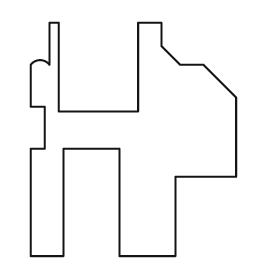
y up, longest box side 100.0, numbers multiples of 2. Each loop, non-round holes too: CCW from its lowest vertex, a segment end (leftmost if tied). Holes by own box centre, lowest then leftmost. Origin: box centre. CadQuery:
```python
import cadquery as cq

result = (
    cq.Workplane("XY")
    .moveTo(-44.0, -50.0)
    .lineTo(-30.0, -50.0)
    .lineTo(-30.0, -4.0)
    .lineTo(-6.0, -4.0)
    .lineTo(-6.0, -50.0)
    .lineTo(18.0, -50.0)
    .lineTo(18.0, -16.0)
    .lineTo(44.0, -16.0)
    .lineTo(44.0, 18.0)
    .lineTo(30.0, 32.0)
    .lineTo(20.0, 32.0)
    .lineTo(12.0, 40.0)
    .lineTo(12.0, 50.0)
    .lineTo(2.0, 50.0)
    .lineTo(2.0, 12.0)
    .lineTo(-32.0, 12.0)
    .lineTo(-32.0, 50.0)
    .lineTo(-36.0, 50.0)
    .lineTo(-36.0, 32.0)
    .threePointArc((-40.0, 34.0), (-44.0, 32.0))
    .lineTo(-44.0, 14.0)
    .lineTo(-38.0, 14.0)
    .lineTo(-38.0, -4.0)
    .lineTo(-44.0, -4.0)
    .close()
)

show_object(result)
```